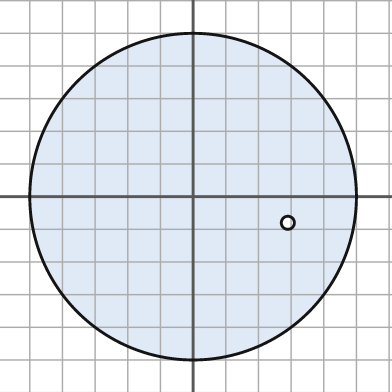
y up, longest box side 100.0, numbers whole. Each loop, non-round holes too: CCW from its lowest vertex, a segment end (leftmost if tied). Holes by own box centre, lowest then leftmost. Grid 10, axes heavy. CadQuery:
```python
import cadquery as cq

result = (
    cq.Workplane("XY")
    .moveTo(0.0, 0.0)
    .circle(50.0)
    .moveTo(29.0, -8.0)
    .circle(2.0)
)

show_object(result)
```